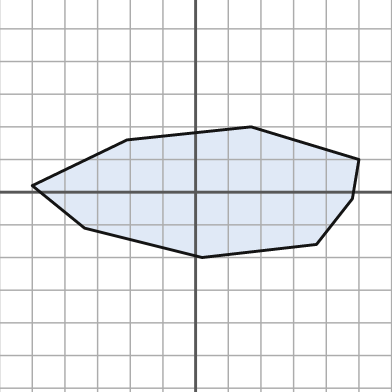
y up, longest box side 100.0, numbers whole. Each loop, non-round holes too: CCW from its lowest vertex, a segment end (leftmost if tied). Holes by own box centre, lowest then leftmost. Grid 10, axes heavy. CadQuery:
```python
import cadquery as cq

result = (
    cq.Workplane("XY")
    .moveTo(2.0, -20.0)
    .lineTo(37.0, -16.0)
    .lineTo(48.0, -2.0)
    .lineTo(50.0, 10.0)
    .lineTo(17.0, 20.0)
    .lineTo(-21.0, 16.0)
    .lineTo(-50.0, 2.0)
    .lineTo(-34.0, -11.0)
    .close()
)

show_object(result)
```